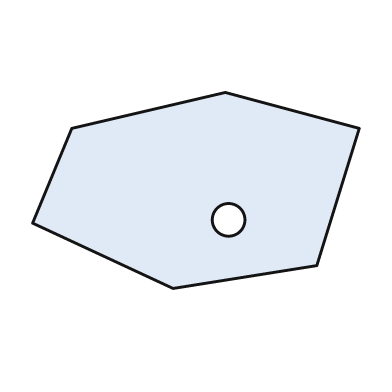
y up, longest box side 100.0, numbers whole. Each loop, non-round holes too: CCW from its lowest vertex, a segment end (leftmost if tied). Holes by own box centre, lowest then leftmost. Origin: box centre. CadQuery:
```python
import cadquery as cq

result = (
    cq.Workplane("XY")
    .moveTo(-7.0, -30.0)
    .lineTo(37.0, -23.0)
    .lineTo(50.0, 19.0)
    .lineTo(9.0, 30.0)
    .lineTo(-38.0, 19.0)
    .lineTo(-50.0, -10.0)
    .close()
    .moveTo(10.0, -9.0)
    .circle(5.0)
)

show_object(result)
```